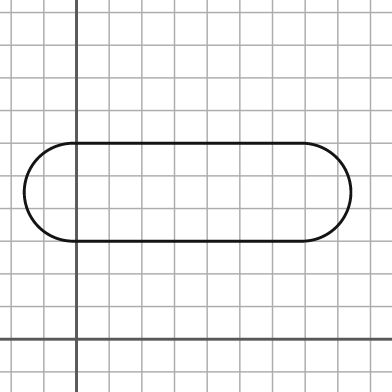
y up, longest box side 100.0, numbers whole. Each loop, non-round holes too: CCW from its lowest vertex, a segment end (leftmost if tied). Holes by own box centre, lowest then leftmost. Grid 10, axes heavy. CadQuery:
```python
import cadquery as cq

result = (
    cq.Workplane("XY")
    .moveTo(-1.0, 30.0)
    .lineTo(69.0, 30.0)
    .threePointArc((84.0, 45.0), (69.0, 60.0))
    .lineTo(-1.0, 60.0)
    .threePointArc((-16.0, 45.0), (-1.0, 30.0))
    .close()
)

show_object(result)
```